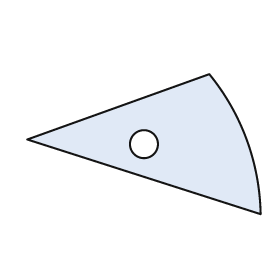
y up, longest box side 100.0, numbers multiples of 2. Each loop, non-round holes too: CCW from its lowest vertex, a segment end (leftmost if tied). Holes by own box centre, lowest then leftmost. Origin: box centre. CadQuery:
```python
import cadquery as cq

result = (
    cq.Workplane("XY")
    .moveTo(50.0, -30.0)
    .threePointArc((44.0, 2.0), (28.0, 30.0))
    .lineTo(-50.0, 2.0)
    .close()
    .moveTo(0.0, 0.0)
    .circle(6.0)
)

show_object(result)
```